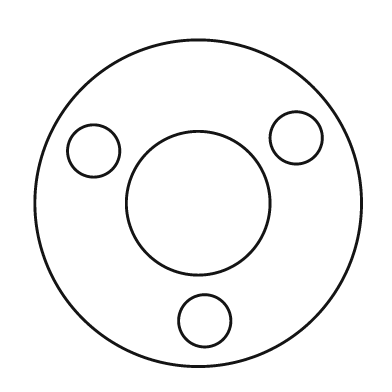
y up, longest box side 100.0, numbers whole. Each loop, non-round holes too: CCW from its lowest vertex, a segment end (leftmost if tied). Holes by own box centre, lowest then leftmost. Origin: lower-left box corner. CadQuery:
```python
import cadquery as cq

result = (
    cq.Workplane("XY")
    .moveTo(50.0, 50.0)
    .circle(50.0)
    .moveTo(52.0, 14.0)
    .circle(8.0)
    .moveTo(50.0, 50.0)
    .circle(22.0)
    .moveTo(18.0, 66.0)
    .circle(8.0)
    .moveTo(80.0, 70.0)
    .circle(8.0)
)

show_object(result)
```